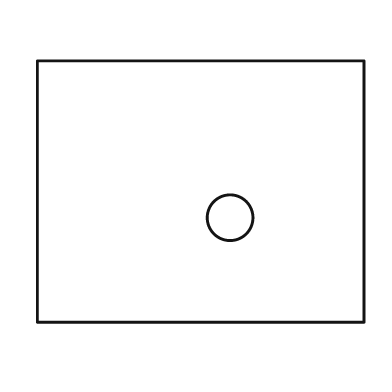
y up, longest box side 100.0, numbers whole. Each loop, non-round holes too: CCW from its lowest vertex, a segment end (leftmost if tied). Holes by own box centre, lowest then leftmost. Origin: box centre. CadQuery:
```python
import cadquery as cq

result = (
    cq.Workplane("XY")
    .moveTo(-50.0, -40.0)
    .lineTo(50.0, -40.0)
    .lineTo(50.0, 40.0)
    .lineTo(-50.0, 40.0)
    .close()
    .moveTo(9.0, -8.0)
    .circle(7.0)
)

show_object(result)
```